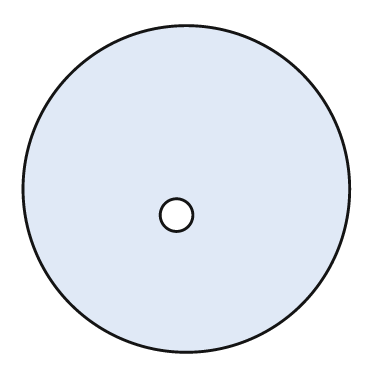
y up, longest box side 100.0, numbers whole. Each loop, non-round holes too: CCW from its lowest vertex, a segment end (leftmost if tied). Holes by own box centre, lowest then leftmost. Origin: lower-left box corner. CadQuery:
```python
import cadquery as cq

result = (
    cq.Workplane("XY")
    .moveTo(50.0, 50.0)
    .circle(50.0)
    .moveTo(47.0, 42.0)
    .circle(5.0)
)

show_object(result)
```